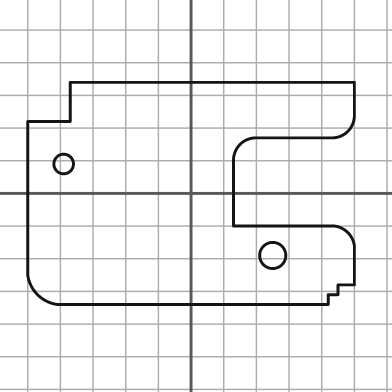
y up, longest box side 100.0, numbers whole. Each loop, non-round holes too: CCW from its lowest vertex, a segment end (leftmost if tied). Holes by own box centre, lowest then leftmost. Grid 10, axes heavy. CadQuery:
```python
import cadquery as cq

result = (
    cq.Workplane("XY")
    .moveTo(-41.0, -34.0)
    .lineTo(42.0, -34.0)
    .lineTo(42.0, -31.0)
    .lineTo(45.0, -31.0)
    .lineTo(45.0, -28.0)
    .lineTo(50.0, -28.0)
    .lineTo(50.0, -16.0)
    .threePointArc((48.0, -12.0), (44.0, -10.0))
    .lineTo(13.0, -10.0)
    .lineTo(13.0, 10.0)
    .threePointArc((15.0, 15.0), (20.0, 17.0))
    .lineTo(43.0, 17.0)
    .threePointArc((48.0, 19.0), (50.0, 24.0))
    .lineTo(50.0, 34.0)
    .lineTo(-37.0, 34.0)
    .lineTo(-37.0, 22.0)
    .lineTo(-50.0, 22.0)
    .lineTo(-50.0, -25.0)
    .threePointArc((-47.0, -31.0), (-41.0, -34.0))
    .close()
    .moveTo(25.0, -19.0)
    .circle(4.0)
    .moveTo(-39.0, 9.0)
    .circle(3.0)
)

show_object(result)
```